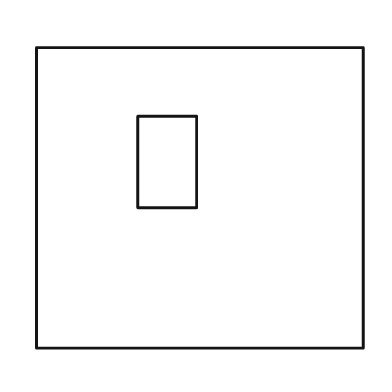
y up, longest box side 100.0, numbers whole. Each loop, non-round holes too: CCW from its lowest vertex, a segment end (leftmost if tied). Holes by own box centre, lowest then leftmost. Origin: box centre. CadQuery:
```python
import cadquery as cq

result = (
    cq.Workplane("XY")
    .moveTo(-50.0, -46.0)
    .lineTo(50.0, -46.0)
    .lineTo(50.0, 46.0)
    .lineTo(-50.0, 46.0)
    .close()
    .moveTo(-19.0, -3.0)
    .lineTo(-1.0, -3.0)
    .lineTo(-1.0, 25.0)
    .lineTo(-19.0, 25.0)
    .close()
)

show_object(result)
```